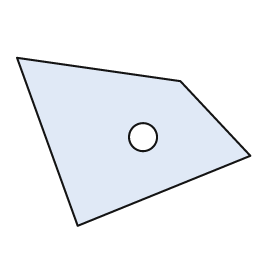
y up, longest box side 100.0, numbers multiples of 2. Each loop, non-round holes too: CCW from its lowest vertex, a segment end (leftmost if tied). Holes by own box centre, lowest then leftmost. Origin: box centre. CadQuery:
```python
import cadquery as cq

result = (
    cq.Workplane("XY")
    .moveTo(-24.0, -36.0)
    .lineTo(50.0, -6.0)
    .lineTo(20.0, 26.0)
    .lineTo(-50.0, 36.0)
    .close()
    .moveTo(4.0, 2.0)
    .circle(6.0)
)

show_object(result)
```